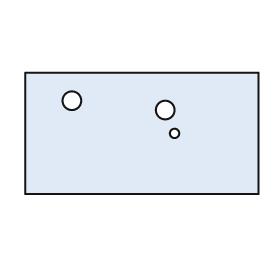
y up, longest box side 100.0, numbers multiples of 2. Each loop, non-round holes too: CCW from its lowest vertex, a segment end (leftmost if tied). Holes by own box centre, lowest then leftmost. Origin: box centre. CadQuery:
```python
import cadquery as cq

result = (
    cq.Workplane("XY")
    .moveTo(-50.0, -26.0)
    .lineTo(50.0, -26.0)
    .lineTo(50.0, 26.0)
    .lineTo(-50.0, 26.0)
    .close()
    .moveTo(14.0, 0.0)
    .circle(2.0)
    .moveTo(10.0, 10.0)
    .circle(4.0)
    .moveTo(-30.0, 14.0)
    .circle(4.0)
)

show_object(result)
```